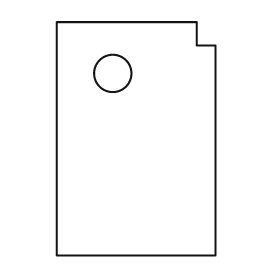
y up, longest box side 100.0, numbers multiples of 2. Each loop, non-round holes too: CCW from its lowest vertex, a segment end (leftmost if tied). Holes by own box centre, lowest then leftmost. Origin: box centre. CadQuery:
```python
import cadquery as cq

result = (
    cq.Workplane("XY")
    .moveTo(-34.0, -50.0)
    .lineTo(34.0, -50.0)
    .lineTo(34.0, 40.0)
    .lineTo(26.0, 40.0)
    .lineTo(26.0, 50.0)
    .lineTo(-34.0, 50.0)
    .close()
    .moveTo(-10.0, 28.0)
    .circle(8.0)
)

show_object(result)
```